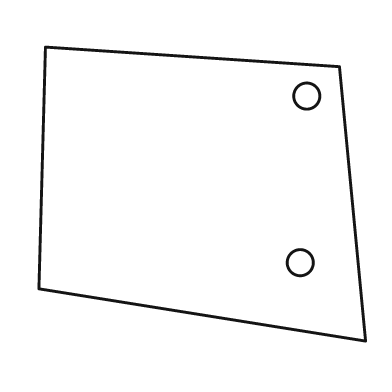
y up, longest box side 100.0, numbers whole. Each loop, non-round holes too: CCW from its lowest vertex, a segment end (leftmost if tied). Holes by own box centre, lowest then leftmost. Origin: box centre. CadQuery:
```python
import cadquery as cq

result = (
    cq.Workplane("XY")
    .moveTo(50.0, -45.0)
    .lineTo(42.0, 39.0)
    .lineTo(-48.0, 45.0)
    .lineTo(-50.0, -29.0)
    .close()
    .moveTo(30.0, -21.0)
    .circle(4.0)
    .moveTo(32.0, 30.0)
    .circle(4.0)
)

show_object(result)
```